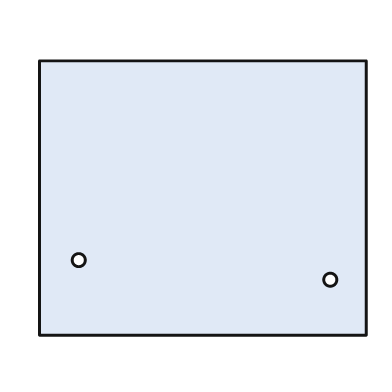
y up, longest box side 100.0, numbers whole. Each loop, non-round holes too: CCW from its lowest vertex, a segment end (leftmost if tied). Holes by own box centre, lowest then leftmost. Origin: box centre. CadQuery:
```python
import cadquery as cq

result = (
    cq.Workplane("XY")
    .moveTo(-50.0, -42.0)
    .lineTo(50.0, -42.0)
    .lineTo(50.0, 42.0)
    .lineTo(-50.0, 42.0)
    .close()
    .moveTo(39.0, -25.0)
    .circle(2.0)
    .moveTo(-38.0, -19.0)
    .circle(2.0)
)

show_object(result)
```